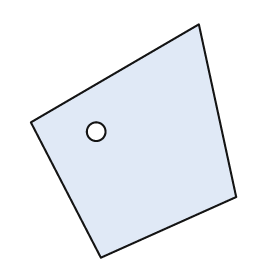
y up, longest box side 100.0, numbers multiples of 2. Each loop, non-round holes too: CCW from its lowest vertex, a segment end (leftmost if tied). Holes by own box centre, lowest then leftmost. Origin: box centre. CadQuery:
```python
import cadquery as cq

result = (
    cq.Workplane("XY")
    .moveTo(-14.0, -50.0)
    .lineTo(44.0, -24.0)
    .lineTo(28.0, 50.0)
    .lineTo(-44.0, 8.0)
    .close()
    .moveTo(-16.0, 4.0)
    .circle(4.0)
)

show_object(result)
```